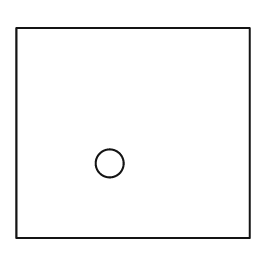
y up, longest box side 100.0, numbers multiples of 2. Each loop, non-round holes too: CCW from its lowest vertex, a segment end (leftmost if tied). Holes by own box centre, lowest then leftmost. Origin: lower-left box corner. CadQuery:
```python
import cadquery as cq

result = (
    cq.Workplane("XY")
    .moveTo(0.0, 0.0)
    .lineTo(100.0, 0.0)
    .lineTo(100.0, 90.0)
    .lineTo(0.0, 90.0)
    .close()
    .moveTo(40.0, 32.0)
    .circle(6.0)
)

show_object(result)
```